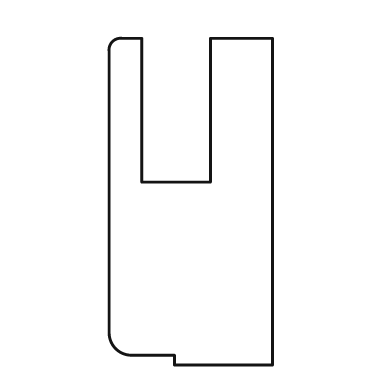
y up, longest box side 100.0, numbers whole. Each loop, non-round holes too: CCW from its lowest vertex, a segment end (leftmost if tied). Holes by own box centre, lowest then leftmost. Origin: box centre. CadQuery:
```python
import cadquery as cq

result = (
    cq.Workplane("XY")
    .moveTo(-5.0, -50.0)
    .lineTo(25.0, -50.0)
    .lineTo(25.0, 50.0)
    .lineTo(6.0, 50.0)
    .lineTo(6.0, 6.0)
    .lineTo(-15.0, 6.0)
    .lineTo(-15.0, 50.0)
    .lineTo(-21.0, 50.0)
    .threePointArc((-24.0, 49.0), (-25.0, 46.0))
    .lineTo(-25.0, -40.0)
    .threePointArc((-23.0, -45.0), (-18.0, -47.0))
    .lineTo(-5.0, -47.0)
    .close()
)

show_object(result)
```